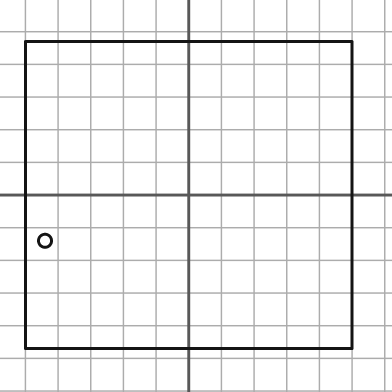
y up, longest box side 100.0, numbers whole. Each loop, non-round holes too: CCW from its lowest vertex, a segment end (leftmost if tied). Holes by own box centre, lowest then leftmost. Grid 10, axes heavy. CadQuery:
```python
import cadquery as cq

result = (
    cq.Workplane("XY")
    .moveTo(-50.0, -47.0)
    .lineTo(50.0, -47.0)
    .lineTo(50.0, 47.0)
    .lineTo(-50.0, 47.0)
    .close()
    .moveTo(-44.0, -14.0)
    .circle(2.0)
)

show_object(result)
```